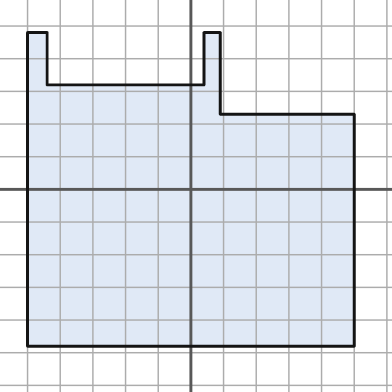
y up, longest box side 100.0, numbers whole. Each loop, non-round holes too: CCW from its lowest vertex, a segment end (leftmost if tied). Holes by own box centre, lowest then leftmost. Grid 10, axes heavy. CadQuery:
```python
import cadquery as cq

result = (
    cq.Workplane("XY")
    .moveTo(-50.0, -48.0)
    .lineTo(50.0, -48.0)
    .lineTo(50.0, 23.0)
    .lineTo(9.0, 23.0)
    .lineTo(9.0, 48.0)
    .lineTo(4.0, 48.0)
    .lineTo(4.0, 32.0)
    .lineTo(-44.0, 32.0)
    .lineTo(-44.0, 48.0)
    .lineTo(-50.0, 48.0)
    .close()
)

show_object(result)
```